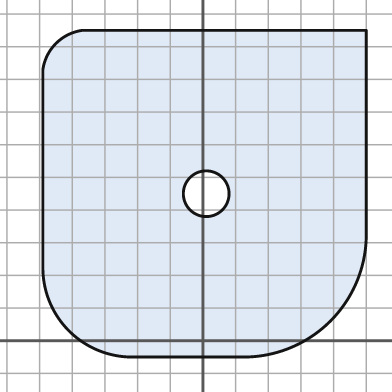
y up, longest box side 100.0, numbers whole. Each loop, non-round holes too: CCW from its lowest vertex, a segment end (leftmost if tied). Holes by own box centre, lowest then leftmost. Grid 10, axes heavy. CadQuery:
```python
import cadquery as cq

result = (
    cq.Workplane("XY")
    .moveTo(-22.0, -5.0)
    .lineTo(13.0, -5.0)
    .threePointArc((39.0, 6.0), (50.0, 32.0))
    .lineTo(50.0, 95.0)
    .lineTo(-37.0, 95.0)
    .threePointArc((-45.0, 91.0), (-49.0, 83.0))
    .lineTo(-49.0, 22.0)
    .threePointArc((-41.0, 3.0), (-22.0, -5.0))
    .close()
    .moveTo(1.0, 45.0)
    .circle(7.0)
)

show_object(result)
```